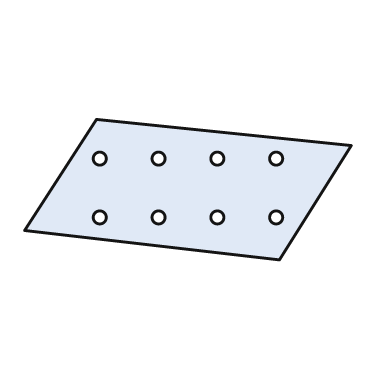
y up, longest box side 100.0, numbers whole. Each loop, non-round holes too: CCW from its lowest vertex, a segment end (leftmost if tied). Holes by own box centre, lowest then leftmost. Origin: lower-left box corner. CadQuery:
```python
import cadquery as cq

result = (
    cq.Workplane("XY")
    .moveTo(78.0, 0.0)
    .lineTo(100.0, 35.0)
    .lineTo(22.0, 43.0)
    .lineTo(0.0, 9.0)
    .close()
    .moveTo(23.0, 13.0)
    .circle(2.0)
    .moveTo(41.0, 13.0)
    .circle(2.0)
    .moveTo(59.0, 13.0)
    .circle(2.0)
    .moveTo(77.0, 13.0)
    .circle(2.0)
    .moveTo(23.0, 31.0)
    .circle(2.0)
    .moveTo(41.0, 31.0)
    .circle(2.0)
    .moveTo(59.0, 31.0)
    .circle(2.0)
    .moveTo(77.0, 31.0)
    .circle(2.0)
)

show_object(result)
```